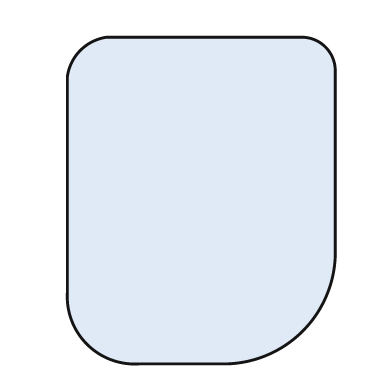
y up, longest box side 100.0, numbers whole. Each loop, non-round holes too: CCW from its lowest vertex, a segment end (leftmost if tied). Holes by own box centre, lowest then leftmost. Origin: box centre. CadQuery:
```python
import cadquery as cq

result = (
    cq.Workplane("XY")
    .moveTo(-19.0, -50.0)
    .lineTo(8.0, -50.0)
    .threePointArc((31.0, -40.0), (41.0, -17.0))
    .lineTo(41.0, 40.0)
    .threePointArc((38.0, 47.0), (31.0, 50.0))
    .lineTo(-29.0, 50.0)
    .threePointArc((-37.0, 46.0), (-41.0, 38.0))
    .lineTo(-41.0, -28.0)
    .threePointArc((-35.0, -44.0), (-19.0, -50.0))
    .close()
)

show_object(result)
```